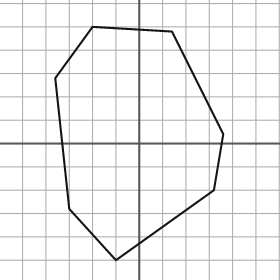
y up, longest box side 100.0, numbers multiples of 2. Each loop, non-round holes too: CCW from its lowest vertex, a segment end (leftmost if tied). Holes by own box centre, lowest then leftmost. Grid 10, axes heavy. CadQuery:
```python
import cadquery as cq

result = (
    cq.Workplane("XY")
    .moveTo(-10.0, -50.0)
    .lineTo(32.0, -20.0)
    .lineTo(36.0, 4.0)
    .lineTo(14.0, 48.0)
    .lineTo(-20.0, 50.0)
    .lineTo(-36.0, 28.0)
    .lineTo(-30.0, -28.0)
    .close()
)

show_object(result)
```